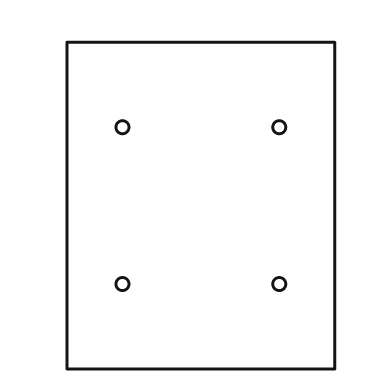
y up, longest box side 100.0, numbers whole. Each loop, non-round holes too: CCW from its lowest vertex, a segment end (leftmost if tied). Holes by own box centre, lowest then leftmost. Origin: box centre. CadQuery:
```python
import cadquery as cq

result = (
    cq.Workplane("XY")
    .moveTo(-41.0, -50.0)
    .lineTo(41.0, -50.0)
    .lineTo(41.0, 50.0)
    .lineTo(-41.0, 50.0)
    .close()
    .moveTo(-24.0, -24.0)
    .circle(2.0)
    .moveTo(24.0, -24.0)
    .circle(2.0)
    .moveTo(-24.0, 24.0)
    .circle(2.0)
    .moveTo(24.0, 24.0)
    .circle(2.0)
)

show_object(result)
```